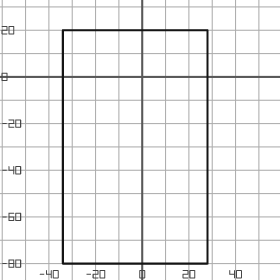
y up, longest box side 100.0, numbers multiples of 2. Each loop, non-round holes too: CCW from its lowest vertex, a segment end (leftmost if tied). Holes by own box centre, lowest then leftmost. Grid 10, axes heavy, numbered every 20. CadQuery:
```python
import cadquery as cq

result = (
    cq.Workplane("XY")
    .moveTo(-34.0, -80.0)
    .lineTo(28.0, -80.0)
    .lineTo(28.0, 20.0)
    .lineTo(-34.0, 20.0)
    .close()
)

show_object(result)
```